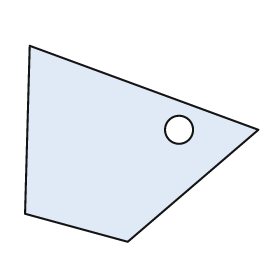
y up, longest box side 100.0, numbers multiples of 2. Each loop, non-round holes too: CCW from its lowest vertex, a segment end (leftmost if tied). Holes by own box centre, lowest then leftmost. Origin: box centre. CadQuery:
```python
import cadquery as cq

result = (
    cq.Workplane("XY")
    .moveTo(-6.0, -42.0)
    .lineTo(50.0, 6.0)
    .lineTo(-48.0, 42.0)
    .lineTo(-50.0, -30.0)
    .close()
    .moveTo(16.0, 6.0)
    .circle(6.0)
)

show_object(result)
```